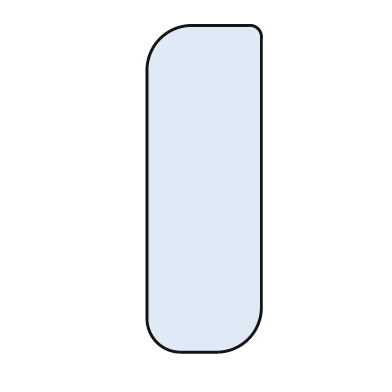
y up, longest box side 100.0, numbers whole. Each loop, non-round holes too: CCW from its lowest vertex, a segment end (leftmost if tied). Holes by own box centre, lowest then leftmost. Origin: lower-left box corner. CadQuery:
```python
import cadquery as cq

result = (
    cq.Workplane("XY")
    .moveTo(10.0, 0.0)
    .lineTo(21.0, 0.0)
    .threePointArc((31.0, 4.0), (35.0, 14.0))
    .lineTo(35.0, 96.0)
    .threePointArc((34.0, 99.0), (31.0, 100.0))
    .lineTo(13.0, 100.0)
    .threePointArc((4.0, 96.0), (0.0, 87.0))
    .lineTo(0.0, 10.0)
    .threePointArc((3.0, 3.0), (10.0, 0.0))
    .close()
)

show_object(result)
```